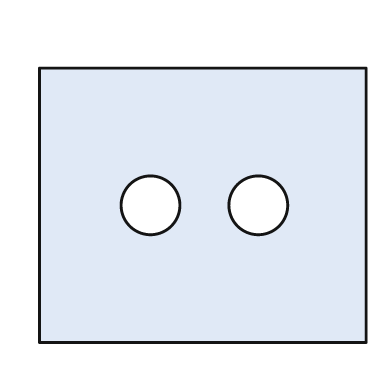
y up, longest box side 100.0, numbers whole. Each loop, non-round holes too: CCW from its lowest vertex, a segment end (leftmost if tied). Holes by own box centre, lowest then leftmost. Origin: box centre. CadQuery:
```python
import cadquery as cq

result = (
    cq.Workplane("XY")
    .moveTo(-50.0, -42.0)
    .lineTo(50.0, -42.0)
    .lineTo(50.0, 42.0)
    .lineTo(-50.0, 42.0)
    .close()
    .moveTo(-16.0, 0.0)
    .circle(9.0)
    .moveTo(17.0, 0.0)
    .circle(9.0)
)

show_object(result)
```